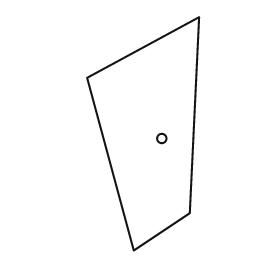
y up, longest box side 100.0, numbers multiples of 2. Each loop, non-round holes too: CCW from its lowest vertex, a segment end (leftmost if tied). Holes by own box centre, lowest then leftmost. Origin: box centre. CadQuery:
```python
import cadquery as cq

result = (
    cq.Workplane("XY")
    .moveTo(-4.0, -50.0)
    .lineTo(20.0, -34.0)
    .lineTo(24.0, 50.0)
    .lineTo(-24.0, 24.0)
    .close()
    .moveTo(8.0, -2.0)
    .circle(2.0)
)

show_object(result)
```